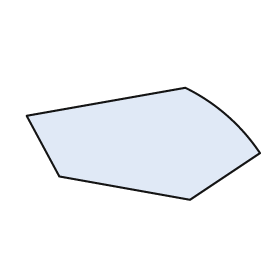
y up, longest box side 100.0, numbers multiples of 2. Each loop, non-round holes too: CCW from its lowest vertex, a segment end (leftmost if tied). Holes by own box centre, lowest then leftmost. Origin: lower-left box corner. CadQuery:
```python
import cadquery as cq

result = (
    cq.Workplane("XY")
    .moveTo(70.0, 0.0)
    .lineTo(100.0, 20.0)
    .threePointArc((86.0, 36.0), (68.0, 48.0))
    .lineTo(0.0, 36.0)
    .lineTo(14.0, 10.0)
    .close()
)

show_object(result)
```